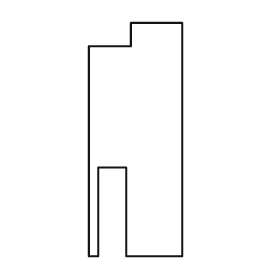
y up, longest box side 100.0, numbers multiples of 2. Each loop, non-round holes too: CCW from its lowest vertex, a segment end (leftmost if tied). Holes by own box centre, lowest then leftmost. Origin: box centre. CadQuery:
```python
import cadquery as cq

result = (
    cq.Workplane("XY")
    .moveTo(-20.0, -50.0)
    .lineTo(-16.0, -50.0)
    .lineTo(-16.0, -12.0)
    .lineTo(-4.0, -12.0)
    .lineTo(-4.0, -50.0)
    .lineTo(20.0, -50.0)
    .lineTo(20.0, 50.0)
    .lineTo(-2.0, 50.0)
    .lineTo(-2.0, 40.0)
    .lineTo(-20.0, 40.0)
    .close()
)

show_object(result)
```